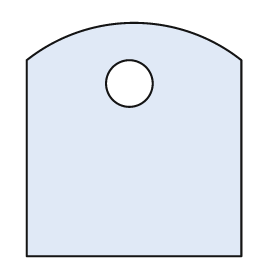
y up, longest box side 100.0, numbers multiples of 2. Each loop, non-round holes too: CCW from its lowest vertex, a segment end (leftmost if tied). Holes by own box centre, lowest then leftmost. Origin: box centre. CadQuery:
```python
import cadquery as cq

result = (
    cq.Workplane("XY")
    .moveTo(-46.0, -50.0)
    .lineTo(46.0, -50.0)
    .lineTo(46.0, 34.0)
    .threePointArc((0.0, 50.0), (-46.0, 34.0))
    .close()
    .moveTo(-2.0, 24.0)
    .circle(10.0)
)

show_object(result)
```